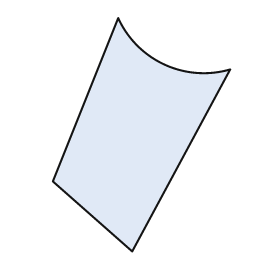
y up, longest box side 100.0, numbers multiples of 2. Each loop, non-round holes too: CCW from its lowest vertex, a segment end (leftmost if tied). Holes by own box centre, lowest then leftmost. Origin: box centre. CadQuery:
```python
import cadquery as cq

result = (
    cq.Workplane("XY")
    .moveTo(-4.0, -50.0)
    .lineTo(38.0, 28.0)
    .threePointArc((10.0, 30.0), (-10.0, 50.0))
    .lineTo(-38.0, -20.0)
    .close()
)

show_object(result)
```